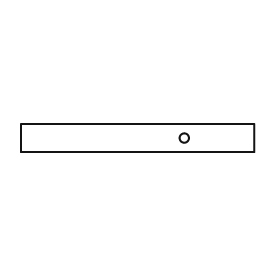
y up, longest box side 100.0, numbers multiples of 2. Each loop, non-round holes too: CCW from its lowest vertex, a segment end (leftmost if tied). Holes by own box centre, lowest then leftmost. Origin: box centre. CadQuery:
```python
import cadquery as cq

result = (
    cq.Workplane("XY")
    .moveTo(-50.0, -6.0)
    .lineTo(50.0, -6.0)
    .lineTo(50.0, 6.0)
    .lineTo(-50.0, 6.0)
    .close()
    .moveTo(20.0, 0.0)
    .circle(2.0)
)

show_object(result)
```